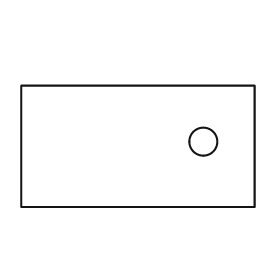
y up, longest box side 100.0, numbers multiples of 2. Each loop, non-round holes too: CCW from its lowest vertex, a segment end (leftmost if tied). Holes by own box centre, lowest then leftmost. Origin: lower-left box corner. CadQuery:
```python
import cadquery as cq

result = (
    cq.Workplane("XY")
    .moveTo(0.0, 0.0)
    .lineTo(100.0, 0.0)
    .lineTo(100.0, 52.0)
    .lineTo(0.0, 52.0)
    .close()
    .moveTo(78.0, 28.0)
    .circle(6.0)
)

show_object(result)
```